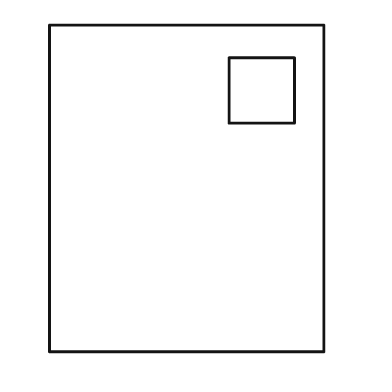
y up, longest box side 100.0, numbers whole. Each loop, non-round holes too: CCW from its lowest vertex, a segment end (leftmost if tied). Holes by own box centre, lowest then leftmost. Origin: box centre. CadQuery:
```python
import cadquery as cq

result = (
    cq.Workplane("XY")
    .moveTo(-42.0, -50.0)
    .lineTo(42.0, -50.0)
    .lineTo(42.0, 50.0)
    .lineTo(-42.0, 50.0)
    .close()
    .moveTo(13.0, 20.0)
    .lineTo(33.0, 20.0)
    .lineTo(33.0, 40.0)
    .lineTo(13.0, 40.0)
    .close()
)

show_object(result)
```